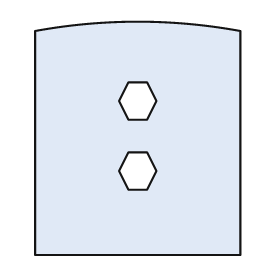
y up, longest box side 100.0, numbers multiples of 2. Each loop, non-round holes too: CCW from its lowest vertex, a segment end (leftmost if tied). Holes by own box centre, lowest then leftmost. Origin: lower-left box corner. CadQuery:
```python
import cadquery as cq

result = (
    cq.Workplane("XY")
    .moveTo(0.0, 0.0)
    .lineTo(88.0, 0.0)
    .lineTo(88.0, 96.0)
    .threePointArc((44.0, 100.0), (0.0, 96.0))
    .close()
    .moveTo(40.0, 28.0)
    .lineTo(48.0, 28.0)
    .lineTo(52.0, 36.0)
    .lineTo(48.0, 44.0)
    .lineTo(40.0, 44.0)
    .lineTo(36.0, 36.0)
    .close()
    .moveTo(40.0, 58.0)
    .lineTo(48.0, 58.0)
    .lineTo(52.0, 66.0)
    .lineTo(48.0, 74.0)
    .lineTo(40.0, 74.0)
    .lineTo(36.0, 66.0)
    .close()
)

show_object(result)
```